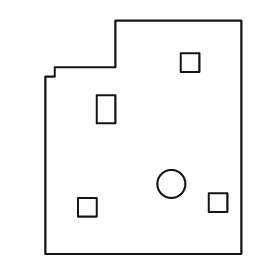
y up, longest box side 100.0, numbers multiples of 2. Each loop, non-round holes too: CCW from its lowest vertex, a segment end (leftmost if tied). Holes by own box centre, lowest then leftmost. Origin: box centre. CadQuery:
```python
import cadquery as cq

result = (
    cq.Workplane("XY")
    .moveTo(-42.0, -50.0)
    .lineTo(42.0, -50.0)
    .lineTo(42.0, 50.0)
    .lineTo(-12.0, 50.0)
    .lineTo(-12.0, 30.0)
    .lineTo(-38.0, 30.0)
    .lineTo(-38.0, 26.0)
    .lineTo(-42.0, 26.0)
    .close()
    .moveTo(-28.0, -34.0)
    .lineTo(-20.0, -34.0)
    .lineTo(-20.0, -26.0)
    .lineTo(-28.0, -26.0)
    .close()
    .moveTo(28.0, -32.0)
    .lineTo(36.0, -32.0)
    .lineTo(36.0, -24.0)
    .lineTo(28.0, -24.0)
    .close()
    .moveTo(12.0, -20.0)
    .circle(6.0)
    .moveTo(-20.0, 6.0)
    .lineTo(-12.0, 6.0)
    .lineTo(-12.0, 18.0)
    .lineTo(-20.0, 18.0)
    .close()
    .moveTo(16.0, 28.0)
    .lineTo(24.0, 28.0)
    .lineTo(24.0, 36.0)
    .lineTo(16.0, 36.0)
    .close()
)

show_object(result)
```